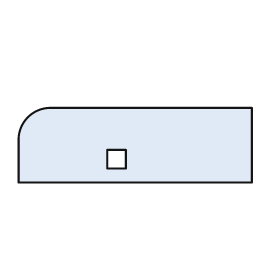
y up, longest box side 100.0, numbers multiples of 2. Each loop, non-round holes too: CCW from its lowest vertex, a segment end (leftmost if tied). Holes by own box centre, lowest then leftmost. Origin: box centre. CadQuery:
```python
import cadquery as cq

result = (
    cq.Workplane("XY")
    .moveTo(-50.0, -16.0)
    .lineTo(50.0, -16.0)
    .lineTo(50.0, 16.0)
    .lineTo(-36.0, 16.0)
    .threePointArc((-46.0, 12.0), (-50.0, 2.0))
    .close()
    .moveTo(-12.0, -10.0)
    .lineTo(-4.0, -10.0)
    .lineTo(-4.0, -2.0)
    .lineTo(-12.0, -2.0)
    .close()
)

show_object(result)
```